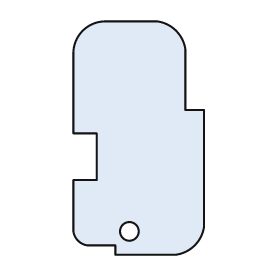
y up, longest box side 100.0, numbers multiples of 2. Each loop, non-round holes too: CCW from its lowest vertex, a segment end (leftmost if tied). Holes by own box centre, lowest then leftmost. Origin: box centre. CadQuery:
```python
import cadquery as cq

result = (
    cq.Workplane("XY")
    .moveTo(-10.0, -50.0)
    .lineTo(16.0, -50.0)
    .threePointArc((24.0, -46.0), (28.0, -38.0))
    .lineTo(28.0, 12.0)
    .lineTo(20.0, 12.0)
    .lineTo(20.0, 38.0)
    .threePointArc((16.0, 46.0), (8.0, 50.0))
    .lineTo(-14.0, 50.0)
    .threePointArc((-24.0, 46.0), (-28.0, 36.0))
    .lineTo(-28.0, 2.0)
    .lineTo(-18.0, 2.0)
    .lineTo(-18.0, -18.0)
    .lineTo(-28.0, -18.0)
    .lineTo(-28.0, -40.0)
    .threePointArc((-26.0, -44.0), (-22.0, -46.0))
    .lineTo(-10.0, -46.0)
    .close()
    .moveTo(-4.0, -40.0)
    .circle(4.0)
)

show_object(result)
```